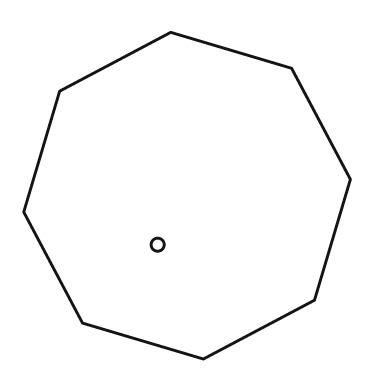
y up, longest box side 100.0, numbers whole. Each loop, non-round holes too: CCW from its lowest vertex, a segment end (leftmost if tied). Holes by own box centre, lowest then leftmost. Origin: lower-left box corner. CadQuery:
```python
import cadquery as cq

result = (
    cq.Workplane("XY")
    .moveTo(55.0, 0.0)
    .lineTo(89.0, 18.0)
    .lineTo(100.0, 55.0)
    .lineTo(82.0, 89.0)
    .lineTo(45.0, 100.0)
    .lineTo(11.0, 82.0)
    .lineTo(0.0, 45.0)
    .lineTo(18.0, 11.0)
    .close()
    .moveTo(41.0, 35.0)
    .circle(2.0)
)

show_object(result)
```